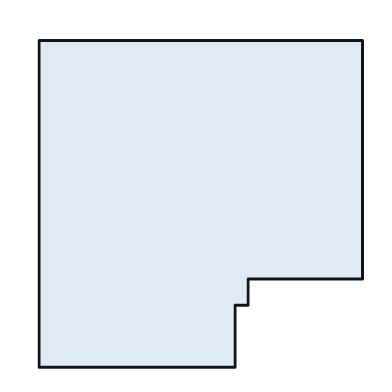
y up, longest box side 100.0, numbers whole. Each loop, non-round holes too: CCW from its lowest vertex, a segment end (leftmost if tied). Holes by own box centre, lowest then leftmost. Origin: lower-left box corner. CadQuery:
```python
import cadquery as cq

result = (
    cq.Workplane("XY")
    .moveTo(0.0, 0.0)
    .lineTo(60.0, 0.0)
    .lineTo(60.0, 19.0)
    .lineTo(64.0, 19.0)
    .lineTo(64.0, 27.0)
    .lineTo(99.0, 27.0)
    .lineTo(99.0, 100.0)
    .lineTo(0.0, 100.0)
    .close()
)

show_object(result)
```